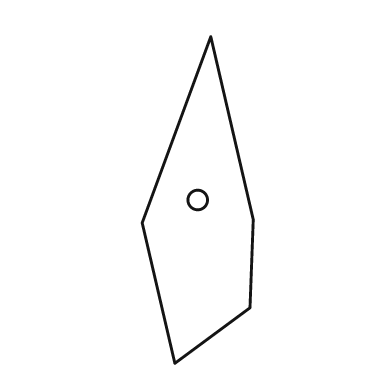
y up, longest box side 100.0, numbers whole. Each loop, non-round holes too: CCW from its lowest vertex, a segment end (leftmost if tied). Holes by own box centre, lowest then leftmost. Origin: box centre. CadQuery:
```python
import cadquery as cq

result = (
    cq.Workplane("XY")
    .moveTo(-7.0, -50.0)
    .lineTo(16.0, -33.0)
    .lineTo(17.0, -6.0)
    .lineTo(4.0, 50.0)
    .lineTo(-17.0, -7.0)
    .close()
    .moveTo(0.0, 0.0)
    .circle(3.0)
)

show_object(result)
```